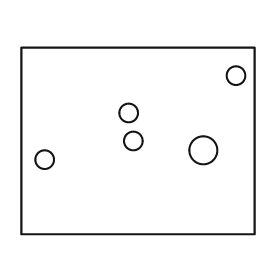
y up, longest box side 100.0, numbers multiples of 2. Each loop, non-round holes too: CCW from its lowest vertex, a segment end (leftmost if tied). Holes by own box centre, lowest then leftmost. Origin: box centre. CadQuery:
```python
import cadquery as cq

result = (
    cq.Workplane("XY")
    .moveTo(-50.0, -40.0)
    .lineTo(50.0, -40.0)
    .lineTo(50.0, 40.0)
    .lineTo(-50.0, 40.0)
    .close()
    .moveTo(-40.0, -8.0)
    .circle(4.0)
    .moveTo(28.0, -4.0)
    .circle(6.0)
    .moveTo(-2.0, 0.0)
    .circle(4.0)
    .moveTo(-4.0, 12.0)
    .circle(4.0)
    .moveTo(42.0, 28.0)
    .circle(4.0)
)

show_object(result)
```